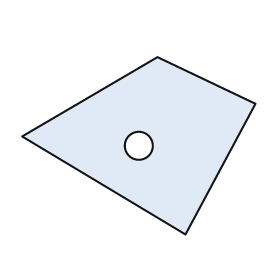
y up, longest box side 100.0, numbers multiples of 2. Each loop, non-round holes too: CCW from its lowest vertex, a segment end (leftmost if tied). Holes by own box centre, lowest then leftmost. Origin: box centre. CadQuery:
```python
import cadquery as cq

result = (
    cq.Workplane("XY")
    .moveTo(20.0, -38.0)
    .lineTo(50.0, 18.0)
    .lineTo(8.0, 38.0)
    .lineTo(-50.0, 4.0)
    .close()
    .moveTo(0.0, 0.0)
    .circle(6.0)
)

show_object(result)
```